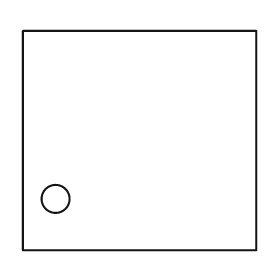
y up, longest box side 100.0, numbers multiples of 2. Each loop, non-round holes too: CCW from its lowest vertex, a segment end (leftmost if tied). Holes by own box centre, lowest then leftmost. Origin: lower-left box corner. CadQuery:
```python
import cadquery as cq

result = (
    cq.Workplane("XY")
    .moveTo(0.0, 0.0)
    .lineTo(100.0, 0.0)
    .lineTo(100.0, 94.0)
    .lineTo(0.0, 94.0)
    .close()
    .moveTo(14.0, 22.0)
    .circle(6.0)
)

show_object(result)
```